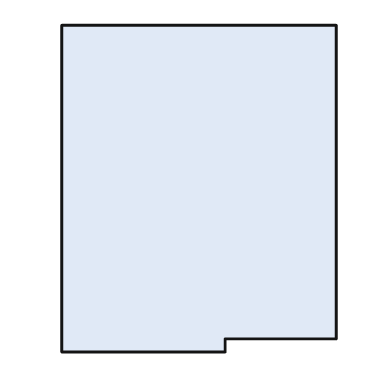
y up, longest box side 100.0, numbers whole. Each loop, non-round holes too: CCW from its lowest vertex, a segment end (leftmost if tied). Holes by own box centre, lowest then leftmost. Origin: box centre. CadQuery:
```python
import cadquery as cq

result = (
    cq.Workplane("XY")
    .moveTo(-42.0, -50.0)
    .lineTo(8.0, -50.0)
    .lineTo(8.0, -46.0)
    .lineTo(42.0, -46.0)
    .lineTo(42.0, 50.0)
    .lineTo(-42.0, 50.0)
    .close()
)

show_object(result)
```